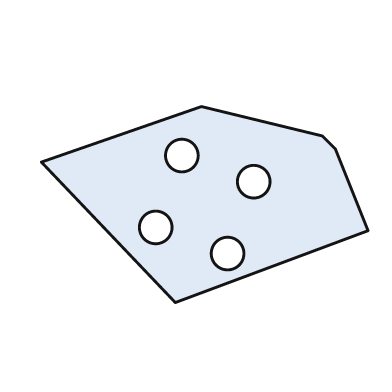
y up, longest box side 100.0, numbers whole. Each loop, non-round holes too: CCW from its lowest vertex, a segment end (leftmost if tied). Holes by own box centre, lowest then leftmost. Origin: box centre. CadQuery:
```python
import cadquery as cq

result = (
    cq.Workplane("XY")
    .moveTo(-9.0, -30.0)
    .lineTo(50.0, -8.0)
    .lineTo(40.0, 17.0)
    .lineTo(36.0, 21.0)
    .lineTo(-1.0, 30.0)
    .lineTo(-50.0, 13.0)
    .close()
    .moveTo(7.0, -15.0)
    .circle(5.0)
    .moveTo(-15.0, -7.0)
    .circle(5.0)
    .moveTo(15.0, 7.0)
    .circle(5.0)
    .moveTo(-7.0, 15.0)
    .circle(5.0)
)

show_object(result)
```